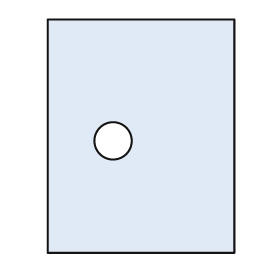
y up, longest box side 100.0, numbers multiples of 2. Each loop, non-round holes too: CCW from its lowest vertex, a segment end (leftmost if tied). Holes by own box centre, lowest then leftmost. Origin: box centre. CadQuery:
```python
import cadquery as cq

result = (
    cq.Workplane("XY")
    .moveTo(-40.0, -50.0)
    .lineTo(40.0, -50.0)
    .lineTo(40.0, 50.0)
    .lineTo(-40.0, 50.0)
    .close()
    .moveTo(-12.0, -2.0)
    .circle(8.0)
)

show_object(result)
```